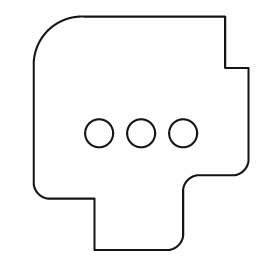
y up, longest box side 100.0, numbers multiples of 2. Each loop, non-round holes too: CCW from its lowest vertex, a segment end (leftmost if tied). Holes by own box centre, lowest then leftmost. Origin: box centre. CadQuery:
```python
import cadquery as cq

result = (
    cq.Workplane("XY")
    .moveTo(-20.0, -50.0)
    .lineTo(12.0, -50.0)
    .threePointArc((16.0, -48.0), (18.0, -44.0))
    .lineTo(18.0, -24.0)
    .threePointArc((20.0, -20.0), (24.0, -18.0))
    .lineTo(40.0, -18.0)
    .threePointArc((44.0, -16.0), (46.0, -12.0))
    .lineTo(46.0, 28.0)
    .lineTo(36.0, 28.0)
    .lineTo(36.0, 50.0)
    .lineTo(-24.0, 50.0)
    .threePointArc((-40.0, 44.0), (-46.0, 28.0))
    .lineTo(-46.0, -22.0)
    .threePointArc((-44.0, -26.0), (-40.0, -28.0))
    .lineTo(-20.0, -28.0)
    .close()
    .moveTo(-18.0, 0.0)
    .circle(6.0)
    .moveTo(0.0, 0.0)
    .circle(6.0)
    .moveTo(18.0, 0.0)
    .circle(6.0)
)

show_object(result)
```